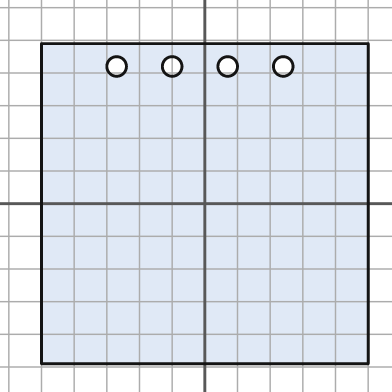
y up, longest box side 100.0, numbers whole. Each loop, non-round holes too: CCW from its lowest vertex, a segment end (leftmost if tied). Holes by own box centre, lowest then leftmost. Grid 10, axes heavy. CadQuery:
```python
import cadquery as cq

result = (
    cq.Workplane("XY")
    .moveTo(-50.0, -49.0)
    .lineTo(50.0, -49.0)
    .lineTo(50.0, 49.0)
    .lineTo(-50.0, 49.0)
    .close()
    .moveTo(-27.0, 42.0)
    .circle(3.0)
    .moveTo(-10.0, 42.0)
    .circle(3.0)
    .moveTo(7.0, 42.0)
    .circle(3.0)
    .moveTo(24.0, 42.0)
    .circle(3.0)
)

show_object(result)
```